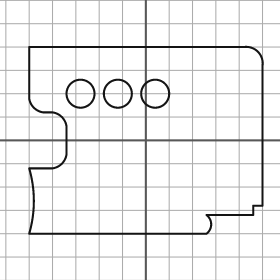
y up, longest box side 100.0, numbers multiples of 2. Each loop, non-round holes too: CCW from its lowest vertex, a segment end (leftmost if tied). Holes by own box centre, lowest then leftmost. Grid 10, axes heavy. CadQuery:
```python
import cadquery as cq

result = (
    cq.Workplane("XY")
    .moveTo(-50.0, -40.0)
    .lineTo(26.0, -40.0)
    .threePointArc((28.0, -36.0), (26.0, -32.0))
    .lineTo(46.0, -32.0)
    .lineTo(46.0, -28.0)
    .lineTo(50.0, -28.0)
    .lineTo(50.0, 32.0)
    .threePointArc((48.0, 38.0), (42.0, 40.0))
    .lineTo(-50.0, 40.0)
    .lineTo(-50.0, 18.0)
    .threePointArc((-48.0, 14.0), (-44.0, 12.0))
    .lineTo(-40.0, 12.0)
    .threePointArc((-36.0, 10.0), (-34.0, 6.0))
    .lineTo(-34.0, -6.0)
    .threePointArc((-36.0, -10.0), (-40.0, -12.0))
    .lineTo(-50.0, -12.0)
    .threePointArc((-48.0, -26.0), (-50.0, -40.0))
    .close()
    .moveTo(-28.0, 20.0)
    .circle(6.0)
    .moveTo(-12.0, 20.0)
    .circle(6.0)
    .moveTo(4.0, 20.0)
    .circle(6.0)
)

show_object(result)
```